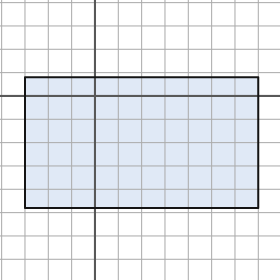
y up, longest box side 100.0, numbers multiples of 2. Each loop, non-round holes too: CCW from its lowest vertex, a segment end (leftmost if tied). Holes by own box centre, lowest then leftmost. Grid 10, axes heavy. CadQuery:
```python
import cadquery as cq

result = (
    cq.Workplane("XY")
    .moveTo(-30.0, -48.0)
    .lineTo(70.0, -48.0)
    .lineTo(70.0, 8.0)
    .lineTo(-30.0, 8.0)
    .close()
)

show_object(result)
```